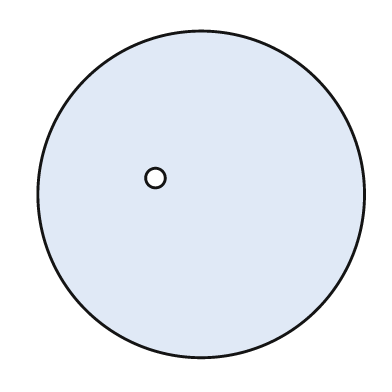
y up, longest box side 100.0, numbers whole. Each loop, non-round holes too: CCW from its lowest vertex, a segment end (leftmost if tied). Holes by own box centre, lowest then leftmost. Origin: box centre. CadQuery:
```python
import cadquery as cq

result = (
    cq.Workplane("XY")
    .moveTo(0.0, 0.0)
    .circle(50.0)
    .moveTo(-14.0, 5.0)
    .circle(3.0)
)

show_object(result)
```